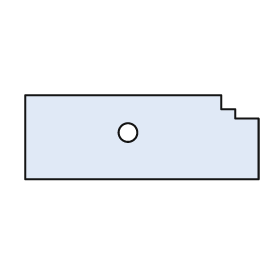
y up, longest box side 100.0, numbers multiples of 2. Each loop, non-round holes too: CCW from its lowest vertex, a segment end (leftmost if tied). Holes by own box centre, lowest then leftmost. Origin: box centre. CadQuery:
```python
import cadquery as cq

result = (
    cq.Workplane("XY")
    .moveTo(-50.0, -18.0)
    .lineTo(50.0, -18.0)
    .lineTo(50.0, 8.0)
    .lineTo(40.0, 8.0)
    .lineTo(40.0, 12.0)
    .lineTo(34.0, 12.0)
    .lineTo(34.0, 18.0)
    .lineTo(-50.0, 18.0)
    .close()
    .moveTo(-6.0, 2.0)
    .circle(4.0)
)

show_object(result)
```